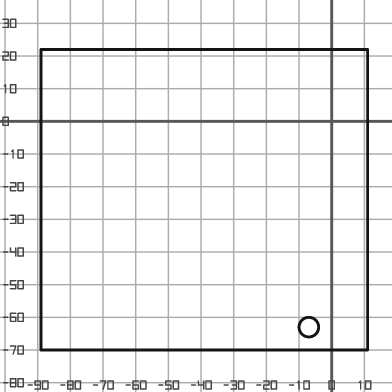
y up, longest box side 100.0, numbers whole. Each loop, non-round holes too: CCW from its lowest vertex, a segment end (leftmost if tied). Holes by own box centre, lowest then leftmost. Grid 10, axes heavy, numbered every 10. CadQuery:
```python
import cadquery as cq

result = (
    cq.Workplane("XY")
    .moveTo(-89.0, -70.0)
    .lineTo(11.0, -70.0)
    .lineTo(11.0, 22.0)
    .lineTo(-89.0, 22.0)
    .close()
    .moveTo(-7.0, -63.0)
    .circle(3.0)
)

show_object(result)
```